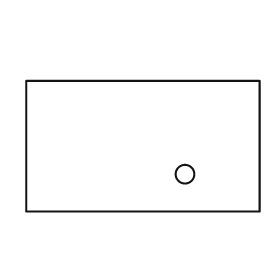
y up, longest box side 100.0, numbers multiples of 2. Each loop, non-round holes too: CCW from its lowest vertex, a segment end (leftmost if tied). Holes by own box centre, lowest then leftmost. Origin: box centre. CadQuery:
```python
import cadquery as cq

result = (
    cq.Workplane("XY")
    .moveTo(-50.0, -28.0)
    .lineTo(50.0, -28.0)
    .lineTo(50.0, 28.0)
    .lineTo(-50.0, 28.0)
    .close()
    .moveTo(18.0, -12.0)
    .circle(4.0)
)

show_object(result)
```